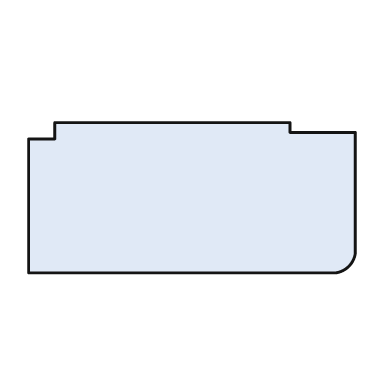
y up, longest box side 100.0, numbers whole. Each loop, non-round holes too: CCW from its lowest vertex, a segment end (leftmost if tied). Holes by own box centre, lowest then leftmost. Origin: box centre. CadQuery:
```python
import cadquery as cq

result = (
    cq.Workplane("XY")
    .moveTo(-50.0, -23.0)
    .lineTo(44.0, -23.0)
    .threePointArc((48.0, -21.0), (50.0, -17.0))
    .lineTo(50.0, 20.0)
    .lineTo(30.0, 20.0)
    .lineTo(30.0, 23.0)
    .lineTo(-42.0, 23.0)
    .lineTo(-42.0, 18.0)
    .lineTo(-50.0, 18.0)
    .close()
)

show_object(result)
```